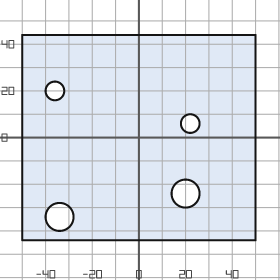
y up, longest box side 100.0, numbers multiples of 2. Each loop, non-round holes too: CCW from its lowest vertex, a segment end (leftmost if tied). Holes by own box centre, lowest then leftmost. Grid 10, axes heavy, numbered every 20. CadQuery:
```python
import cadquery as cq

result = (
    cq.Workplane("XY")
    .moveTo(-50.0, -44.0)
    .lineTo(50.0, -44.0)
    .lineTo(50.0, 44.0)
    .lineTo(-50.0, 44.0)
    .close()
    .moveTo(-34.0, -34.0)
    .circle(6.0)
    .moveTo(20.0, -24.0)
    .circle(6.0)
    .moveTo(22.0, 6.0)
    .circle(4.0)
    .moveTo(-36.0, 20.0)
    .circle(4.0)
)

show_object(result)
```